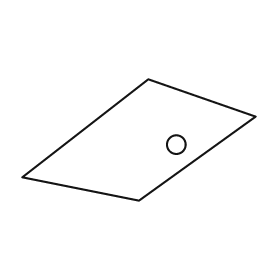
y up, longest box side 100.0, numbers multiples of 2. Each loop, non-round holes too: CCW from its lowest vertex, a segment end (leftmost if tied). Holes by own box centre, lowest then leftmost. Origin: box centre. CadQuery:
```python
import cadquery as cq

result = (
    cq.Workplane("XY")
    .moveTo(0.0, -26.0)
    .lineTo(50.0, 10.0)
    .lineTo(4.0, 26.0)
    .lineTo(-50.0, -16.0)
    .close()
    .moveTo(16.0, -2.0)
    .circle(4.0)
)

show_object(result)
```